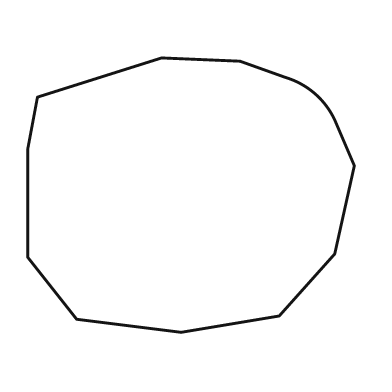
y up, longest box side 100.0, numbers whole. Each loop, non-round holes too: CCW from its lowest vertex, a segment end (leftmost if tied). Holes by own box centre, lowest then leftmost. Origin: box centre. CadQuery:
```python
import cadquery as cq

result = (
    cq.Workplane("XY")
    .moveTo(-3.0, -42.0)
    .lineTo(27.0, -37.0)
    .lineTo(44.0, -18.0)
    .lineTo(50.0, 9.0)
    .lineTo(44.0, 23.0)
    .threePointArc((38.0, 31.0), (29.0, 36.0))
    .lineTo(15.0, 41.0)
    .lineTo(-9.0, 42.0)
    .lineTo(-47.0, 30.0)
    .lineTo(-50.0, 14.0)
    .lineTo(-50.0, -19.0)
    .lineTo(-35.0, -38.0)
    .close()
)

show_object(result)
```